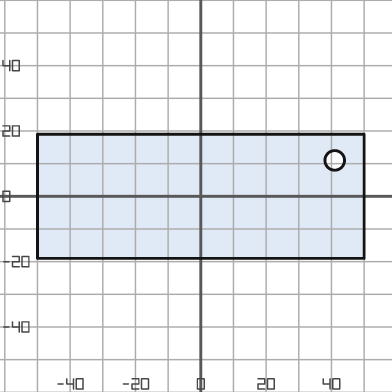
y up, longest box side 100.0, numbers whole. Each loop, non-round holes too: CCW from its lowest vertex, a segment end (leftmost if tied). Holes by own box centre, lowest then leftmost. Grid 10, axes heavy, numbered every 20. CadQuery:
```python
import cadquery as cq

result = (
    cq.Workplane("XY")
    .moveTo(-50.0, -19.0)
    .lineTo(50.0, -19.0)
    .lineTo(50.0, 19.0)
    .lineTo(-50.0, 19.0)
    .close()
    .moveTo(41.0, 11.0)
    .circle(3.0)
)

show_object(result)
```